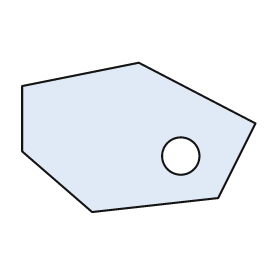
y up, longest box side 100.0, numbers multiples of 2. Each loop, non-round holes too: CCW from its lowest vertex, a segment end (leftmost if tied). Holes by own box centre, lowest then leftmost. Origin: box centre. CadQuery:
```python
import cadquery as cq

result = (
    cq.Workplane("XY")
    .moveTo(-20.0, -32.0)
    .lineTo(34.0, -26.0)
    .lineTo(50.0, 6.0)
    .lineTo(0.0, 32.0)
    .lineTo(-50.0, 22.0)
    .lineTo(-50.0, -6.0)
    .close()
    .moveTo(18.0, -8.0)
    .circle(8.0)
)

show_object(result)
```